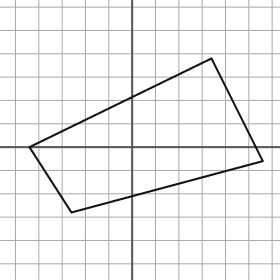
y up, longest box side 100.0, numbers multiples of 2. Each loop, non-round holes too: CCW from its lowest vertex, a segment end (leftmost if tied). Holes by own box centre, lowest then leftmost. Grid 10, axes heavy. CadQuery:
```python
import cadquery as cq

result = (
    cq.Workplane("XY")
    .moveTo(-26.0, -28.0)
    .lineTo(56.0, -6.0)
    .lineTo(34.0, 38.0)
    .lineTo(-44.0, 0.0)
    .close()
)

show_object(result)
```